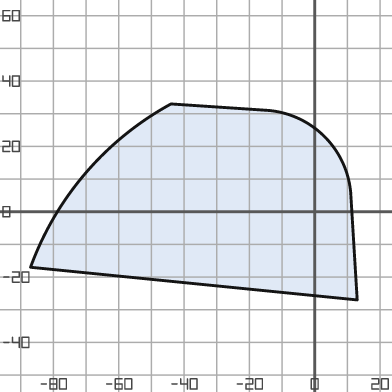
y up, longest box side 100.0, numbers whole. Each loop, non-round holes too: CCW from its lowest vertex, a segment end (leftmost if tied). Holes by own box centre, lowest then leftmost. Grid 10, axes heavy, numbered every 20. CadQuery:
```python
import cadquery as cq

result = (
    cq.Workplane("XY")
    .moveTo(13.0, -27.0)
    .lineTo(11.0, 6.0)
    .threePointArc((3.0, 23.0), (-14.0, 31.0))
    .lineTo(-44.0, 33.0)
    .threePointArc((-70.0, 12.0), (-87.0, -17.0))
    .close()
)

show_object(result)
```